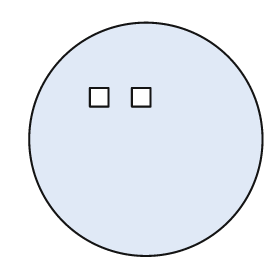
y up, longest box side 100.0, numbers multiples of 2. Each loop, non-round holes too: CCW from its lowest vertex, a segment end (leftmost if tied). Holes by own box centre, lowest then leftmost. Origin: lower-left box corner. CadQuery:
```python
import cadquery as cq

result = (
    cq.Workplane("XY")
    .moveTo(50.0, 50.0)
    .circle(50.0)
    .moveTo(26.0, 64.0)
    .lineTo(34.0, 64.0)
    .lineTo(34.0, 72.0)
    .lineTo(26.0, 72.0)
    .close()
    .moveTo(44.0, 64.0)
    .lineTo(52.0, 64.0)
    .lineTo(52.0, 72.0)
    .lineTo(44.0, 72.0)
    .close()
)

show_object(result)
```